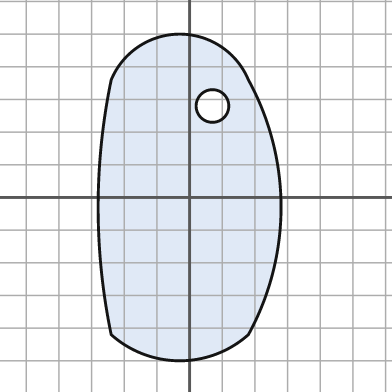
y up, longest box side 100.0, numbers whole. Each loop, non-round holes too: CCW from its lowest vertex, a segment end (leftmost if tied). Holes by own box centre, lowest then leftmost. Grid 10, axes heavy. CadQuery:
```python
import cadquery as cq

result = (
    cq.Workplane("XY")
    .moveTo(-24.0, -42.0)
    .threePointArc((-3.0, -50.0), (18.0, -42.0))
    .threePointArc((28.0, -3.0), (18.0, 36.0))
    .threePointArc((-3.0, 50.0), (-24.0, 36.0))
    .threePointArc((-28.0, -3.0), (-24.0, -42.0))
    .close()
    .moveTo(7.0, 28.0)
    .circle(5.0)
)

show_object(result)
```